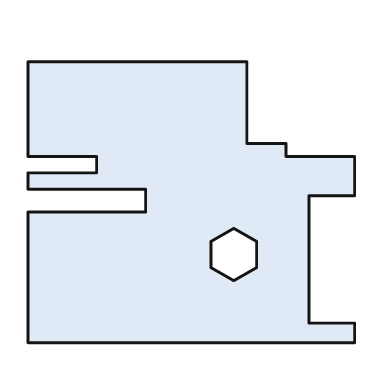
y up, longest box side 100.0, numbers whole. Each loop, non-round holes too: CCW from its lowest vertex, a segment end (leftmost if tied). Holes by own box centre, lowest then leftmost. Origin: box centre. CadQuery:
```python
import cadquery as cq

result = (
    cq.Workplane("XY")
    .moveTo(-50.0, -43.0)
    .lineTo(50.0, -43.0)
    .lineTo(50.0, -37.0)
    .lineTo(36.0, -37.0)
    .lineTo(36.0, 2.0)
    .lineTo(50.0, 2.0)
    .lineTo(50.0, 14.0)
    .lineTo(29.0, 14.0)
    .lineTo(29.0, 18.0)
    .lineTo(17.0, 18.0)
    .lineTo(17.0, 43.0)
    .lineTo(-50.0, 43.0)
    .lineTo(-50.0, 14.0)
    .lineTo(-29.0, 14.0)
    .lineTo(-29.0, 9.0)
    .lineTo(-50.0, 9.0)
    .lineTo(-50.0, 4.0)
    .lineTo(-14.0, 4.0)
    .lineTo(-14.0, -3.0)
    .lineTo(-50.0, -3.0)
    .close()
    .moveTo(13.0, -24.0)
    .lineTo(20.0, -20.0)
    .lineTo(20.0, -12.0)
    .lineTo(13.0, -8.0)
    .lineTo(6.0, -12.0)
    .lineTo(6.0, -20.0)
    .close()
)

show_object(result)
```